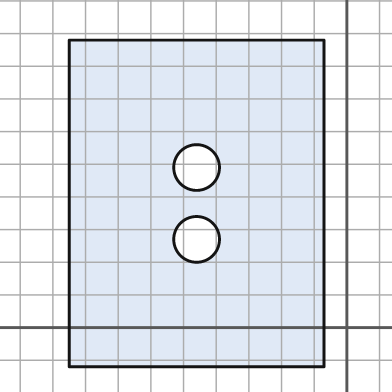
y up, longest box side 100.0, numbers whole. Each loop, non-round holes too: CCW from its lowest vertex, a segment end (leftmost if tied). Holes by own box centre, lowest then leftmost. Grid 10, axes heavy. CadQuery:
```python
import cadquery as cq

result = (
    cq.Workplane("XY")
    .moveTo(-85.0, -12.0)
    .lineTo(-7.0, -12.0)
    .lineTo(-7.0, 88.0)
    .lineTo(-85.0, 88.0)
    .close()
    .moveTo(-46.0, 27.0)
    .circle(7.0)
    .moveTo(-46.0, 49.0)
    .circle(7.0)
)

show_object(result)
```